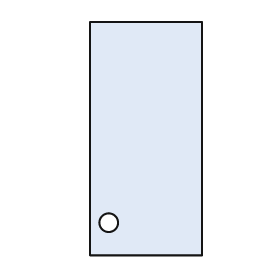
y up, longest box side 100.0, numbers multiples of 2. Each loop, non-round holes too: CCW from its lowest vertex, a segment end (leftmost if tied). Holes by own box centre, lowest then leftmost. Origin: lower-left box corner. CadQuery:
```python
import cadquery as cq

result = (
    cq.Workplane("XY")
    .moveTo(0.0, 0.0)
    .lineTo(48.0, 0.0)
    .lineTo(48.0, 100.0)
    .lineTo(0.0, 100.0)
    .close()
    .moveTo(8.0, 14.0)
    .circle(4.0)
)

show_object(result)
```